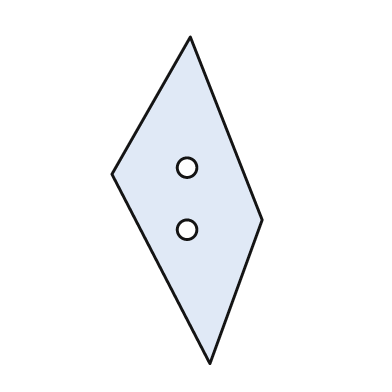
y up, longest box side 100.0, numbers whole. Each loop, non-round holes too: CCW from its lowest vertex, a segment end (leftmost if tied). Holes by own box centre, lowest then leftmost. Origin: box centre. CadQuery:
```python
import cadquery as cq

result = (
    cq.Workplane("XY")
    .moveTo(7.0, -50.0)
    .lineTo(23.0, -6.0)
    .lineTo(1.0, 50.0)
    .lineTo(-23.0, 8.0)
    .close()
    .moveTo(0.0, -9.0)
    .circle(3.0)
    .moveTo(0.0, 10.0)
    .circle(3.0)
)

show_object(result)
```